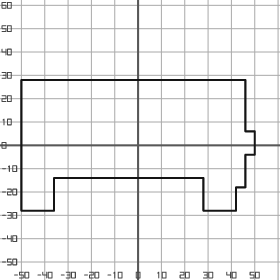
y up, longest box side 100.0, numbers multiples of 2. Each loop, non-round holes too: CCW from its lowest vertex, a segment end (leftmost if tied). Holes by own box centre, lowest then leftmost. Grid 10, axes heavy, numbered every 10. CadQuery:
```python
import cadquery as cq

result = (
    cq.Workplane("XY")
    .moveTo(-50.0, -28.0)
    .lineTo(-36.0, -28.0)
    .lineTo(-36.0, -14.0)
    .lineTo(28.0, -14.0)
    .lineTo(28.0, -28.0)
    .lineTo(42.0, -28.0)
    .lineTo(42.0, -18.0)
    .lineTo(46.0, -18.0)
    .lineTo(46.0, -4.0)
    .lineTo(50.0, -4.0)
    .lineTo(50.0, 6.0)
    .lineTo(46.0, 6.0)
    .lineTo(46.0, 28.0)
    .lineTo(-50.0, 28.0)
    .close()
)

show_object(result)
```